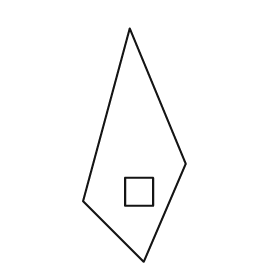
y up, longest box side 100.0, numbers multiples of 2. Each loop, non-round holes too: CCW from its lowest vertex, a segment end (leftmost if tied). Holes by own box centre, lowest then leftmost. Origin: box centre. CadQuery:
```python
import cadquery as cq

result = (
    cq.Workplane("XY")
    .moveTo(4.0, -50.0)
    .lineTo(22.0, -8.0)
    .lineTo(-2.0, 50.0)
    .lineTo(-22.0, -24.0)
    .close()
    .moveTo(-4.0, -26.0)
    .lineTo(8.0, -26.0)
    .lineTo(8.0, -14.0)
    .lineTo(-4.0, -14.0)
    .close()
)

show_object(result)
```